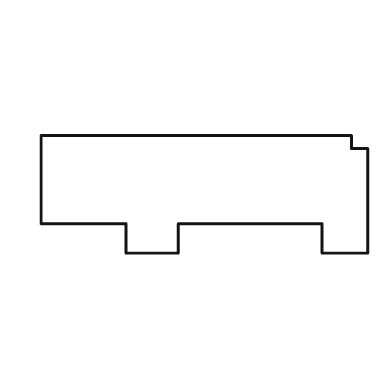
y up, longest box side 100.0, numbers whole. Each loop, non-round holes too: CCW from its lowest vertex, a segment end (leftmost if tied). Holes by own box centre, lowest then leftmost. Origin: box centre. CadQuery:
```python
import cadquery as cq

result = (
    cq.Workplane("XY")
    .moveTo(-24.0, -18.0)
    .lineTo(-8.0, -18.0)
    .lineTo(-8.0, -9.0)
    .lineTo(36.0, -9.0)
    .lineTo(36.0, -18.0)
    .lineTo(50.0, -18.0)
    .lineTo(50.0, 14.0)
    .lineTo(45.0, 14.0)
    .lineTo(45.0, 18.0)
    .lineTo(-50.0, 18.0)
    .lineTo(-50.0, -9.0)
    .lineTo(-24.0, -9.0)
    .close()
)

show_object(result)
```